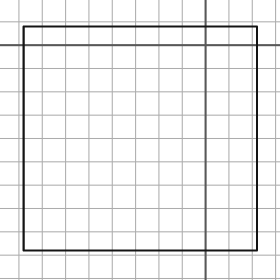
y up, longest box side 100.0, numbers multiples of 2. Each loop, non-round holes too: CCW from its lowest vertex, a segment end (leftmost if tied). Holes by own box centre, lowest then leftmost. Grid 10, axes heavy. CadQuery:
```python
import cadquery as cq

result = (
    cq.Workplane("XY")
    .moveTo(-78.0, -88.0)
    .lineTo(22.0, -88.0)
    .lineTo(22.0, 8.0)
    .lineTo(-78.0, 8.0)
    .close()
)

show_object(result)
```